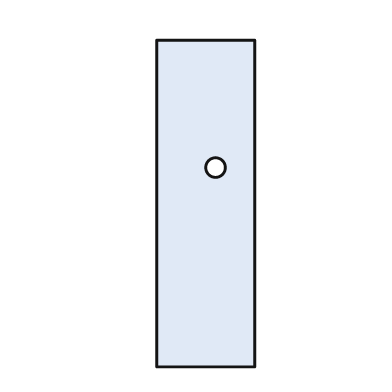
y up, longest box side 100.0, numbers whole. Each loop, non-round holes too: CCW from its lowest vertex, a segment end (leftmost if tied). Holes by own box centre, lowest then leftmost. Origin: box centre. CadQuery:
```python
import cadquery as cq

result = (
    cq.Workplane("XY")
    .moveTo(-15.0, -50.0)
    .lineTo(15.0, -50.0)
    .lineTo(15.0, 50.0)
    .lineTo(-15.0, 50.0)
    .close()
    .moveTo(3.0, 11.0)
    .circle(3.0)
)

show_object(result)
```